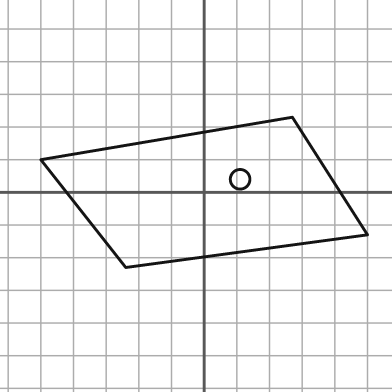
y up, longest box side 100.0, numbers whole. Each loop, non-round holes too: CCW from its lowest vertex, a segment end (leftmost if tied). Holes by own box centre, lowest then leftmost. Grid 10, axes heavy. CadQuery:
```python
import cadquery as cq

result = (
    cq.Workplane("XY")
    .moveTo(-24.0, -23.0)
    .lineTo(50.0, -13.0)
    .lineTo(27.0, 23.0)
    .lineTo(-50.0, 10.0)
    .close()
    .moveTo(11.0, 4.0)
    .circle(3.0)
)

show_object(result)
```